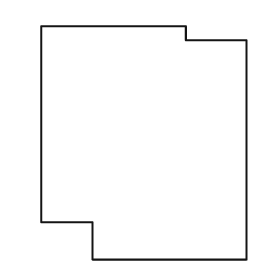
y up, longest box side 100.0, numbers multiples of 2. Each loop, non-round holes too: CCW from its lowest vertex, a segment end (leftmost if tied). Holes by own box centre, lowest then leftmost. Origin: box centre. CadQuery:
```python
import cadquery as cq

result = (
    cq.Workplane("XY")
    .moveTo(-22.0, -50.0)
    .lineTo(44.0, -50.0)
    .lineTo(44.0, 44.0)
    .lineTo(18.0, 44.0)
    .lineTo(18.0, 50.0)
    .lineTo(-44.0, 50.0)
    .lineTo(-44.0, -34.0)
    .lineTo(-22.0, -34.0)
    .close()
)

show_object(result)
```